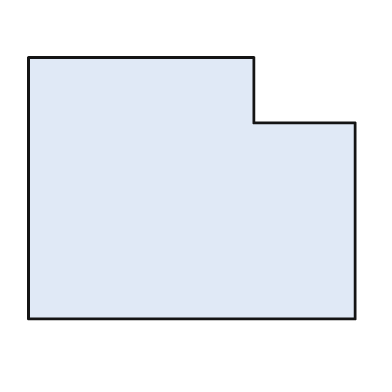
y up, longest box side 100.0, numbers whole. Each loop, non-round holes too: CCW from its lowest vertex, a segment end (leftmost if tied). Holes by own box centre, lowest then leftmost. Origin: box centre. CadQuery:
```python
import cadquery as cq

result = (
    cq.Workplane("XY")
    .moveTo(-50.0, -40.0)
    .lineTo(50.0, -40.0)
    .lineTo(50.0, 20.0)
    .lineTo(19.0, 20.0)
    .lineTo(19.0, 40.0)
    .lineTo(-50.0, 40.0)
    .close()
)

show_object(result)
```